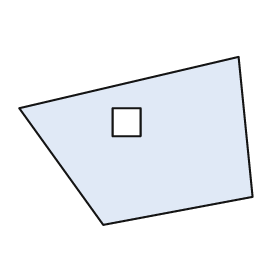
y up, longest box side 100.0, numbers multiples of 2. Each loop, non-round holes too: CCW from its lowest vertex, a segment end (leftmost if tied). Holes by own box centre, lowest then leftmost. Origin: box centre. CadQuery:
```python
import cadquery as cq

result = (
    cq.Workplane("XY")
    .moveTo(-14.0, -36.0)
    .lineTo(50.0, -24.0)
    .lineTo(44.0, 36.0)
    .lineTo(-50.0, 14.0)
    .close()
    .moveTo(-10.0, 2.0)
    .lineTo(2.0, 2.0)
    .lineTo(2.0, 14.0)
    .lineTo(-10.0, 14.0)
    .close()
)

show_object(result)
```